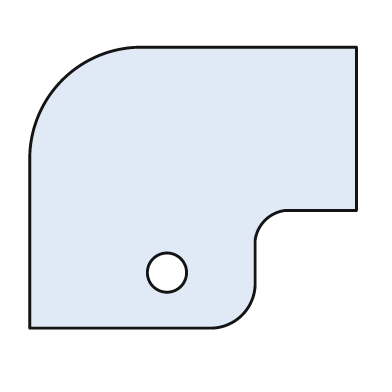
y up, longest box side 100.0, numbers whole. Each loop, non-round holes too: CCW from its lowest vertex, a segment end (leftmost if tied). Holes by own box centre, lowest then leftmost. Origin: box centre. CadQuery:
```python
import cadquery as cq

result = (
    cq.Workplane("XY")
    .moveTo(-50.0, -43.0)
    .lineTo(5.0, -43.0)
    .threePointArc((15.0, -39.0), (19.0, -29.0))
    .lineTo(19.0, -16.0)
    .threePointArc((22.0, -10.0), (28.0, -7.0))
    .lineTo(50.0, -7.0)
    .lineTo(50.0, 43.0)
    .lineTo(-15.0, 43.0)
    .threePointArc((-40.0, 33.0), (-50.0, 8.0))
    .close()
    .moveTo(-8.0, -26.0)
    .circle(6.0)
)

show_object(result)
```